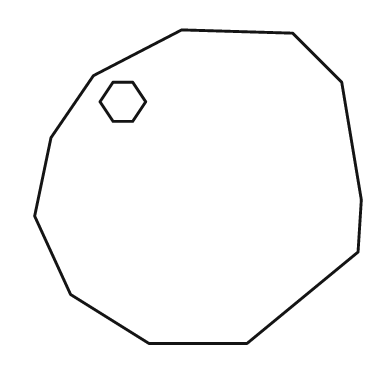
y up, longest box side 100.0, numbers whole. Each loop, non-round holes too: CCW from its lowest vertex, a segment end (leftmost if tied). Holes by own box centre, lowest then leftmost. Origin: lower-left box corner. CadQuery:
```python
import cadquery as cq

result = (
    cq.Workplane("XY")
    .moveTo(35.0, 0.0)
    .lineTo(65.0, 0.0)
    .lineTo(99.0, 28.0)
    .lineTo(100.0, 44.0)
    .lineTo(94.0, 80.0)
    .lineTo(79.0, 95.0)
    .lineTo(45.0, 96.0)
    .lineTo(18.0, 82.0)
    .lineTo(5.0, 63.0)
    .lineTo(0.0, 39.0)
    .lineTo(11.0, 15.0)
    .close()
    .moveTo(24.0, 68.0)
    .lineTo(30.0, 68.0)
    .lineTo(34.0, 74.0)
    .lineTo(30.0, 80.0)
    .lineTo(24.0, 80.0)
    .lineTo(20.0, 74.0)
    .close()
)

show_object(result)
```